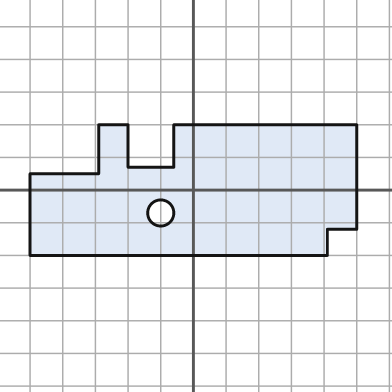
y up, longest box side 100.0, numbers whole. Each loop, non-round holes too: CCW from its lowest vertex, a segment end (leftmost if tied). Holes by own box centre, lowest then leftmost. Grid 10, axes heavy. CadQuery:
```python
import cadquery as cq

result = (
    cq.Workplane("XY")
    .moveTo(-50.0, -20.0)
    .lineTo(41.0, -20.0)
    .lineTo(41.0, -12.0)
    .lineTo(50.0, -12.0)
    .lineTo(50.0, 20.0)
    .lineTo(-6.0, 20.0)
    .lineTo(-6.0, 7.0)
    .lineTo(-20.0, 7.0)
    .lineTo(-20.0, 20.0)
    .lineTo(-29.0, 20.0)
    .lineTo(-29.0, 5.0)
    .lineTo(-50.0, 5.0)
    .close()
    .moveTo(-10.0, -7.0)
    .circle(4.0)
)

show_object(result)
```